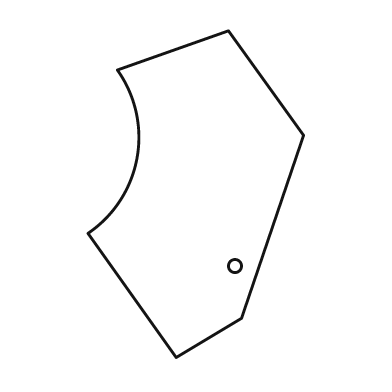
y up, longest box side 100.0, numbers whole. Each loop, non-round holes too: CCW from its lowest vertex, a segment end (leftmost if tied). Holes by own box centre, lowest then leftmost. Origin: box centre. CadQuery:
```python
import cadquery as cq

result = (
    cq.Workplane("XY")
    .moveTo(-6.0, -50.0)
    .lineTo(14.0, -38.0)
    .lineTo(33.0, 18.0)
    .lineTo(10.0, 50.0)
    .lineTo(-24.0, 38.0)
    .threePointArc((-18.0, 11.0), (-33.0, -12.0))
    .close()
    .moveTo(12.0, -22.0)
    .circle(2.0)
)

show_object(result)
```